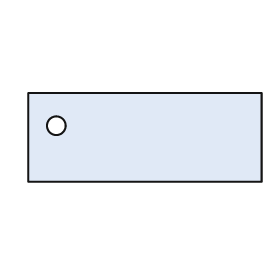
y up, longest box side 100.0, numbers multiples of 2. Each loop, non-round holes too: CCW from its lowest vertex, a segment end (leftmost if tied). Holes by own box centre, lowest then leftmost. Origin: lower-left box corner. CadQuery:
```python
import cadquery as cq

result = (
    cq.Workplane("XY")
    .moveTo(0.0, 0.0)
    .lineTo(100.0, 0.0)
    .lineTo(100.0, 38.0)
    .lineTo(0.0, 38.0)
    .close()
    .moveTo(12.0, 24.0)
    .circle(4.0)
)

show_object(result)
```